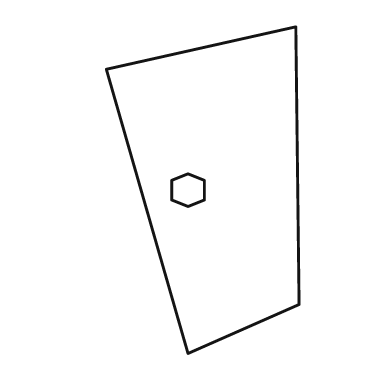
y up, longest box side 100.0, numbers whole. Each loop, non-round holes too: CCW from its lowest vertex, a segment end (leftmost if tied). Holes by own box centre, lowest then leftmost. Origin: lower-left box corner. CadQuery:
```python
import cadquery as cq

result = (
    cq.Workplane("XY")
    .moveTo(25.0, 0.0)
    .lineTo(59.0, 15.0)
    .lineTo(58.0, 100.0)
    .lineTo(0.0, 87.0)
    .close()
    .moveTo(25.0, 45.0)
    .lineTo(30.0, 47.0)
    .lineTo(30.0, 53.0)
    .lineTo(25.0, 55.0)
    .lineTo(20.0, 53.0)
    .lineTo(20.0, 47.0)
    .close()
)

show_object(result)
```